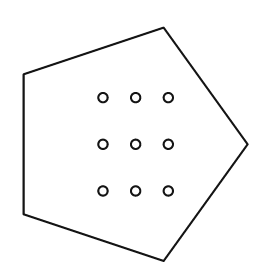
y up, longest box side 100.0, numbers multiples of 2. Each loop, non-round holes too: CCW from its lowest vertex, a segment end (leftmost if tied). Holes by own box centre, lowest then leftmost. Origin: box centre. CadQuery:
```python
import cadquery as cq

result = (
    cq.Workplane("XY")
    .moveTo(12.0, -50.0)
    .lineTo(48.0, 0.0)
    .lineTo(12.0, 50.0)
    .lineTo(-48.0, 30.0)
    .lineTo(-48.0, -30.0)
    .close()
    .moveTo(-14.0, -20.0)
    .circle(2.0)
    .moveTo(0.0, -20.0)
    .circle(2.0)
    .moveTo(14.0, -20.0)
    .circle(2.0)
    .moveTo(-14.0, 0.0)
    .circle(2.0)
    .moveTo(0.0, 0.0)
    .circle(2.0)
    .moveTo(14.0, 0.0)
    .circle(2.0)
    .moveTo(-14.0, 20.0)
    .circle(2.0)
    .moveTo(0.0, 20.0)
    .circle(2.0)
    .moveTo(14.0, 20.0)
    .circle(2.0)
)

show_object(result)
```